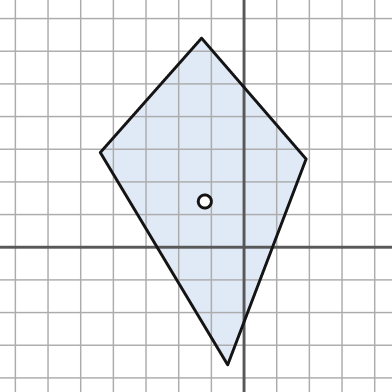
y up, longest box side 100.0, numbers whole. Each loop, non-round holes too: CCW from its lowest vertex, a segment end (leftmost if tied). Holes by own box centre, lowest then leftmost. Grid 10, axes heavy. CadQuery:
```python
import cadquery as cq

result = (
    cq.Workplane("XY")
    .moveTo(-5.0, -36.0)
    .lineTo(19.0, 27.0)
    .lineTo(-13.0, 64.0)
    .lineTo(-44.0, 29.0)
    .close()
    .moveTo(-12.0, 14.0)
    .circle(2.0)
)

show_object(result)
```